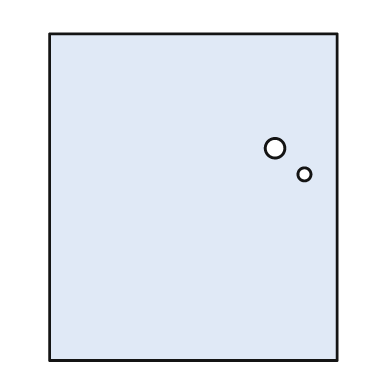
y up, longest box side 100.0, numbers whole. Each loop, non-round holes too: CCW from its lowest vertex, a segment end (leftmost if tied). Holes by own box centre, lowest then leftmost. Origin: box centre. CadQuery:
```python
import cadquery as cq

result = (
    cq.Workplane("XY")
    .moveTo(-44.0, -50.0)
    .lineTo(44.0, -50.0)
    .lineTo(44.0, 50.0)
    .lineTo(-44.0, 50.0)
    .close()
    .moveTo(34.0, 7.0)
    .circle(2.0)
    .moveTo(25.0, 15.0)
    .circle(3.0)
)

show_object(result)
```